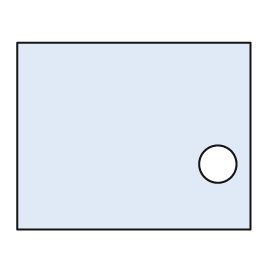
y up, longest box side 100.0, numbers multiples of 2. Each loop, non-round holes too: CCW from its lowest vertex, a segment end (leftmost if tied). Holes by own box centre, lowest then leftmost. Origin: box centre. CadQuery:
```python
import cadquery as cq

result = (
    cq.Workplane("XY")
    .moveTo(-50.0, -40.0)
    .lineTo(50.0, -40.0)
    .lineTo(50.0, 40.0)
    .lineTo(-50.0, 40.0)
    .close()
    .moveTo(36.0, -12.0)
    .circle(8.0)
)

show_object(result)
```